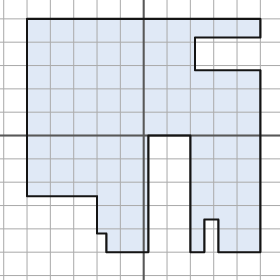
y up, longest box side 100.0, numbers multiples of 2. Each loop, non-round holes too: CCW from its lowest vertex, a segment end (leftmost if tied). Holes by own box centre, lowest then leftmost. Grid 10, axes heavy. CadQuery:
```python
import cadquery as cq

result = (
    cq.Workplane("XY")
    .moveTo(-16.0, -50.0)
    .lineTo(2.0, -50.0)
    .lineTo(2.0, 0.0)
    .lineTo(20.0, 0.0)
    .lineTo(20.0, -50.0)
    .lineTo(26.0, -50.0)
    .lineTo(26.0, -36.0)
    .lineTo(32.0, -36.0)
    .lineTo(32.0, -50.0)
    .lineTo(50.0, -50.0)
    .lineTo(50.0, 28.0)
    .lineTo(22.0, 28.0)
    .lineTo(22.0, 42.0)
    .lineTo(50.0, 42.0)
    .lineTo(50.0, 50.0)
    .lineTo(-50.0, 50.0)
    .lineTo(-50.0, -26.0)
    .lineTo(-20.0, -26.0)
    .lineTo(-20.0, -42.0)
    .lineTo(-16.0, -42.0)
    .close()
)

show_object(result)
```